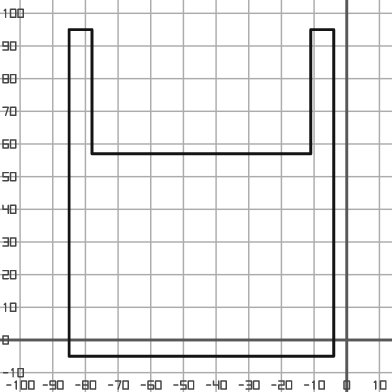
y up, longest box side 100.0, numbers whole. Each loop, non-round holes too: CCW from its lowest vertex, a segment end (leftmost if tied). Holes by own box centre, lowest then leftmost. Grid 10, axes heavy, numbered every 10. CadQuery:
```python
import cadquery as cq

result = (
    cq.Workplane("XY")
    .moveTo(-85.0, -5.0)
    .lineTo(-4.0, -5.0)
    .lineTo(-4.0, 95.0)
    .lineTo(-11.0, 95.0)
    .lineTo(-11.0, 57.0)
    .lineTo(-78.0, 57.0)
    .lineTo(-78.0, 95.0)
    .lineTo(-85.0, 95.0)
    .close()
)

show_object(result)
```